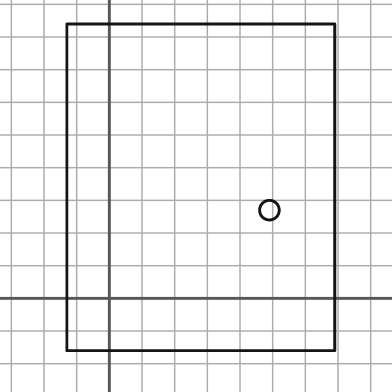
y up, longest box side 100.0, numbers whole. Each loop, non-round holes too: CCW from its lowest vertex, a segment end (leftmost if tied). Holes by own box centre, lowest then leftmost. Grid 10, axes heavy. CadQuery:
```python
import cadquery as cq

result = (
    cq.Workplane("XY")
    .moveTo(-13.0, -16.0)
    .lineTo(69.0, -16.0)
    .lineTo(69.0, 84.0)
    .lineTo(-13.0, 84.0)
    .close()
    .moveTo(49.0, 27.0)
    .circle(3.0)
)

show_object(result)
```